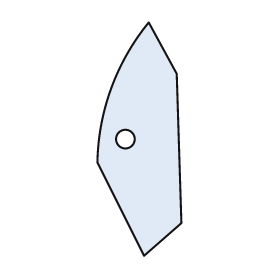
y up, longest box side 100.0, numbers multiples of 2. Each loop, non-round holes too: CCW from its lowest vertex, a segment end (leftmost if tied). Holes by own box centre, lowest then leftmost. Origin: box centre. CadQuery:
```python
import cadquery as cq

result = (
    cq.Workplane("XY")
    .moveTo(2.0, -50.0)
    .lineTo(18.0, -36.0)
    .lineTo(16.0, 28.0)
    .lineTo(4.0, 50.0)
    .threePointArc((-12.0, 22.0), (-18.0, -10.0))
    .close()
    .moveTo(-6.0, 0.0)
    .circle(4.0)
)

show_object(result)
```